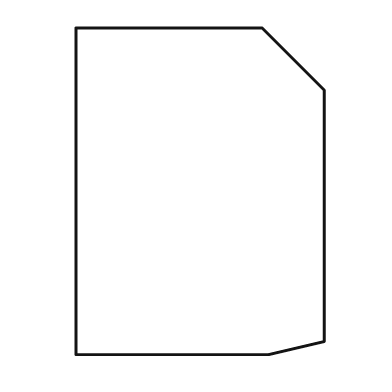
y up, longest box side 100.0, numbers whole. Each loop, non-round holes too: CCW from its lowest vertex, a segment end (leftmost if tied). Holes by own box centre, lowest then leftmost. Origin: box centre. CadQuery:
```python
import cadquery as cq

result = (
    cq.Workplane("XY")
    .moveTo(-38.0, -50.0)
    .lineTo(21.0, -50.0)
    .lineTo(38.0, -46.0)
    .lineTo(38.0, 31.0)
    .lineTo(19.0, 50.0)
    .lineTo(-38.0, 50.0)
    .close()
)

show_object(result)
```